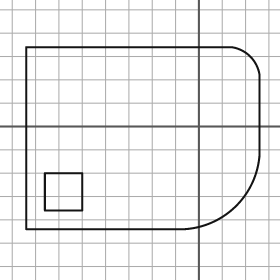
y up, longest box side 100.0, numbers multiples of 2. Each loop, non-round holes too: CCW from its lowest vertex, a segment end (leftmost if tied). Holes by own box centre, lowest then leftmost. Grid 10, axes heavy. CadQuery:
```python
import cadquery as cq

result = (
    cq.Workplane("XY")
    .moveTo(-74.0, -44.0)
    .lineTo(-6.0, -44.0)
    .threePointArc((16.0, -34.0), (26.0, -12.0))
    .lineTo(26.0, 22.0)
    .threePointArc((22.0, 30.0), (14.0, 34.0))
    .lineTo(-74.0, 34.0)
    .close()
    .moveTo(-66.0, -36.0)
    .lineTo(-50.0, -36.0)
    .lineTo(-50.0, -20.0)
    .lineTo(-66.0, -20.0)
    .close()
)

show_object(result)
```